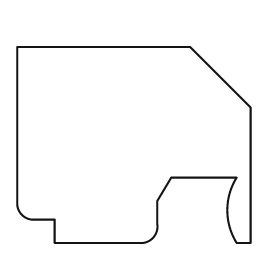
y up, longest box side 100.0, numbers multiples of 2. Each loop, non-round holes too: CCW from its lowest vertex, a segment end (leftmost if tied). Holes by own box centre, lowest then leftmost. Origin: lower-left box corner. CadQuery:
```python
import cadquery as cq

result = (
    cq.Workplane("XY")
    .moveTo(16.0, 0.0)
    .lineTo(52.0, 0.0)
    .threePointArc((58.0, 2.0), (60.0, 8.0))
    .lineTo(60.0, 18.0)
    .lineTo(66.0, 28.0)
    .lineTo(94.0, 28.0)
    .threePointArc((90.0, 14.0), (94.0, 0.0))
    .lineTo(100.0, 0.0)
    .lineTo(100.0, 58.0)
    .lineTo(74.0, 84.0)
    .lineTo(0.0, 84.0)
    .lineTo(0.0, 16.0)
    .threePointArc((2.0, 12.0), (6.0, 10.0))
    .lineTo(16.0, 10.0)
    .close()
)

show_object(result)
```